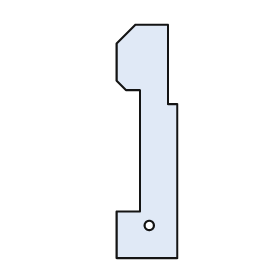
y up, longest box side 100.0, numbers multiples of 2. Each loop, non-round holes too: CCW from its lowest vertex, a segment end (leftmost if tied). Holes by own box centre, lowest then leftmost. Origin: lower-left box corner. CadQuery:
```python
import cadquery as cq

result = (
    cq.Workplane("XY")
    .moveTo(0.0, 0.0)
    .lineTo(26.0, 0.0)
    .lineTo(26.0, 66.0)
    .lineTo(22.0, 66.0)
    .lineTo(22.0, 100.0)
    .lineTo(8.0, 100.0)
    .lineTo(0.0, 92.0)
    .lineTo(0.0, 76.0)
    .lineTo(4.0, 72.0)
    .lineTo(10.0, 72.0)
    .lineTo(10.0, 20.0)
    .lineTo(0.0, 20.0)
    .close()
    .moveTo(14.0, 14.0)
    .circle(2.0)
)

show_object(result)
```